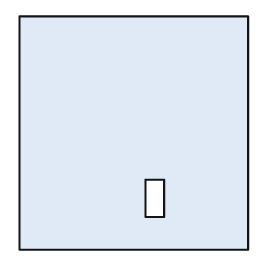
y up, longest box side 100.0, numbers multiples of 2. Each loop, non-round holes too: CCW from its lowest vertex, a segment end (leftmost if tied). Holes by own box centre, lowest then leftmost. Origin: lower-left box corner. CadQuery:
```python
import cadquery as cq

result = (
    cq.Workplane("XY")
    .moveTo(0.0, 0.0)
    .lineTo(98.0, 0.0)
    .lineTo(98.0, 100.0)
    .lineTo(0.0, 100.0)
    .close()
    .moveTo(54.0, 14.0)
    .lineTo(62.0, 14.0)
    .lineTo(62.0, 30.0)
    .lineTo(54.0, 30.0)
    .close()
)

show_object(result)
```